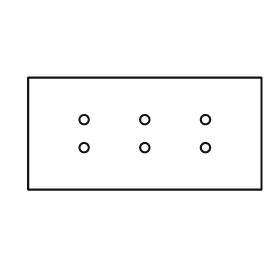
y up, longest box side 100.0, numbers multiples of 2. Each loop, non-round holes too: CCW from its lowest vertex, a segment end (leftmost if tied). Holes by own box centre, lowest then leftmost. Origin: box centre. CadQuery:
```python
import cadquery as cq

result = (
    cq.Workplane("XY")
    .moveTo(-50.0, -24.0)
    .lineTo(50.0, -24.0)
    .lineTo(50.0, 24.0)
    .lineTo(-50.0, 24.0)
    .close()
    .moveTo(-26.0, -6.0)
    .circle(2.0)
    .moveTo(0.0, -6.0)
    .circle(2.0)
    .moveTo(26.0, -6.0)
    .circle(2.0)
    .moveTo(-26.0, 6.0)
    .circle(2.0)
    .moveTo(0.0, 6.0)
    .circle(2.0)
    .moveTo(26.0, 6.0)
    .circle(2.0)
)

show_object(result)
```